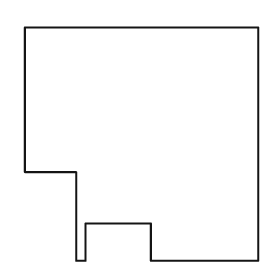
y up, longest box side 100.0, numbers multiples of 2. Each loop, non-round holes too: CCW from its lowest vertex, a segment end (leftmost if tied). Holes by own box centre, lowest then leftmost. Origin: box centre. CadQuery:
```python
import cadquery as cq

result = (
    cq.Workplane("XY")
    .moveTo(-28.0, -50.0)
    .lineTo(-24.0, -50.0)
    .lineTo(-24.0, -34.0)
    .lineTo(4.0, -34.0)
    .lineTo(4.0, -50.0)
    .lineTo(50.0, -50.0)
    .lineTo(50.0, 50.0)
    .lineTo(-50.0, 50.0)
    .lineTo(-50.0, -12.0)
    .lineTo(-28.0, -12.0)
    .close()
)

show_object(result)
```